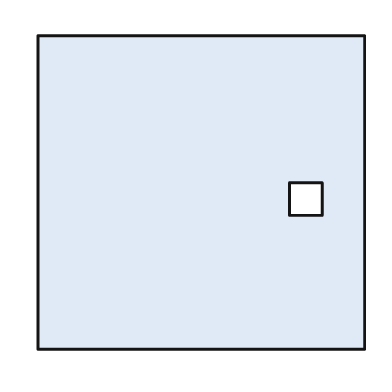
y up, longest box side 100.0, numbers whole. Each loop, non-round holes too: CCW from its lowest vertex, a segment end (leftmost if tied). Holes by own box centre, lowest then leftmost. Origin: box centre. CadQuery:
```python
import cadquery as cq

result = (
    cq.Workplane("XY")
    .moveTo(-50.0, -48.0)
    .lineTo(50.0, -48.0)
    .lineTo(50.0, 48.0)
    .lineTo(-50.0, 48.0)
    .close()
    .moveTo(27.0, -7.0)
    .lineTo(37.0, -7.0)
    .lineTo(37.0, 3.0)
    .lineTo(27.0, 3.0)
    .close()
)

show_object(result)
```